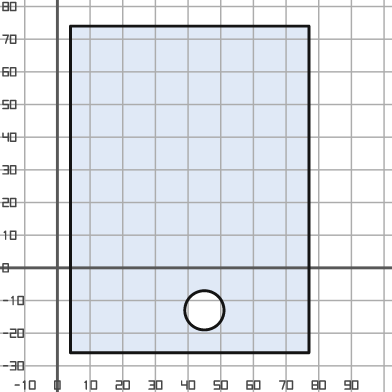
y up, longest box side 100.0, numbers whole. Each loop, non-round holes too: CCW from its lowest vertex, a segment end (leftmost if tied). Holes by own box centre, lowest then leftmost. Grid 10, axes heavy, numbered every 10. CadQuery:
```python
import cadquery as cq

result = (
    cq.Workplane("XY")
    .moveTo(4.0, -26.0)
    .lineTo(77.0, -26.0)
    .lineTo(77.0, 74.0)
    .lineTo(4.0, 74.0)
    .close()
    .moveTo(45.0, -13.0)
    .circle(6.0)
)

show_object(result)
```